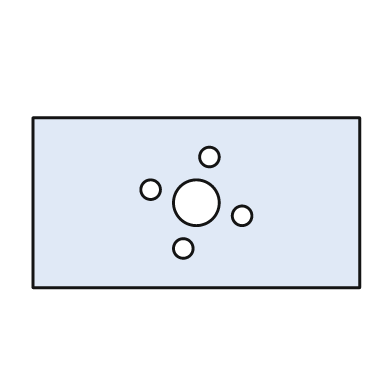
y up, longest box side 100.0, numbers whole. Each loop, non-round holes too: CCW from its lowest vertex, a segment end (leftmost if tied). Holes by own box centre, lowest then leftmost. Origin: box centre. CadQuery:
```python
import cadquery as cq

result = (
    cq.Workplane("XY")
    .moveTo(-50.0, -26.0)
    .lineTo(50.0, -26.0)
    .lineTo(50.0, 26.0)
    .lineTo(-50.0, 26.0)
    .close()
    .moveTo(-4.0, -14.0)
    .circle(3.0)
    .moveTo(14.0, -4.0)
    .circle(3.0)
    .moveTo(0.0, 0.0)
    .circle(7.0)
    .moveTo(-14.0, 4.0)
    .circle(3.0)
    .moveTo(4.0, 14.0)
    .circle(3.0)
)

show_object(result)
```